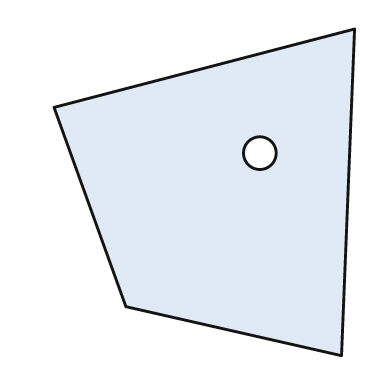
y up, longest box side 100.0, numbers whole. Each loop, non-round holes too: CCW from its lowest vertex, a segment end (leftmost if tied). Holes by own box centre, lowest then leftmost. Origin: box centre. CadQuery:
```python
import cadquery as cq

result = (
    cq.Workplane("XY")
    .moveTo(42.0, -50.0)
    .lineTo(46.0, 50.0)
    .lineTo(-46.0, 26.0)
    .lineTo(-24.0, -35.0)
    .close()
    .moveTo(17.0, 12.0)
    .circle(5.0)
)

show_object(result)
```